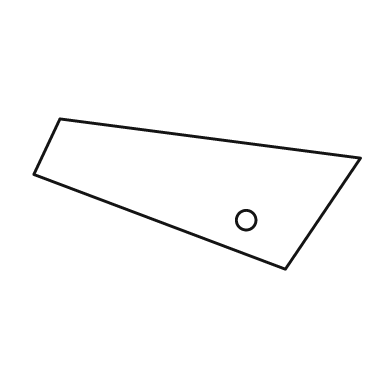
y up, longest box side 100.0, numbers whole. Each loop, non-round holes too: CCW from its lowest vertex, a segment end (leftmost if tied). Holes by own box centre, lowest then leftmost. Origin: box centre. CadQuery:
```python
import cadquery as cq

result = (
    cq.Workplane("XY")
    .moveTo(27.0, -23.0)
    .lineTo(50.0, 11.0)
    .lineTo(-42.0, 23.0)
    .lineTo(-50.0, 6.0)
    .close()
    .moveTo(15.0, -8.0)
    .circle(3.0)
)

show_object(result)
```